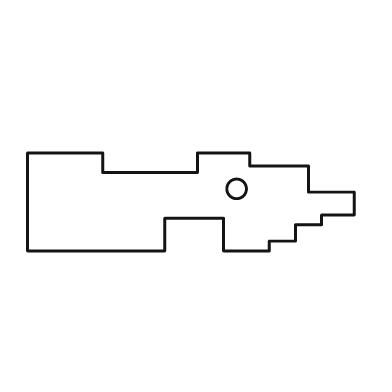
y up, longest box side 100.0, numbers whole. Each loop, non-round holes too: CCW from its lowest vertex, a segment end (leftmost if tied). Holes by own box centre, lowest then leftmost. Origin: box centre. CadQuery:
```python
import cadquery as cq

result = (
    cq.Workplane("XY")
    .moveTo(-50.0, -15.0)
    .lineTo(-8.0, -15.0)
    .lineTo(-8.0, -5.0)
    .lineTo(10.0, -5.0)
    .lineTo(10.0, -15.0)
    .lineTo(24.0, -15.0)
    .lineTo(24.0, -12.0)
    .lineTo(32.0, -12.0)
    .lineTo(32.0, -7.0)
    .lineTo(40.0, -7.0)
    .lineTo(40.0, -4.0)
    .lineTo(50.0, -4.0)
    .lineTo(50.0, 3.0)
    .lineTo(36.0, 3.0)
    .lineTo(36.0, 11.0)
    .lineTo(18.0, 11.0)
    .lineTo(18.0, 15.0)
    .lineTo(2.0, 15.0)
    .lineTo(2.0, 9.0)
    .lineTo(-27.0, 9.0)
    .lineTo(-27.0, 15.0)
    .lineTo(-50.0, 15.0)
    .close()
    .moveTo(14.0, 4.0)
    .circle(3.0)
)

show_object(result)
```